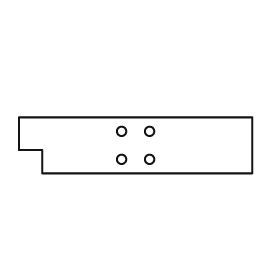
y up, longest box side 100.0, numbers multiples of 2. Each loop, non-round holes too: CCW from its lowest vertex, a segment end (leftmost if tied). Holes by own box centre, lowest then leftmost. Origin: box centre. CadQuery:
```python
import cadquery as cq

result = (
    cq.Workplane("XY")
    .moveTo(-40.0, -12.0)
    .lineTo(50.0, -12.0)
    .lineTo(50.0, 12.0)
    .lineTo(-50.0, 12.0)
    .lineTo(-50.0, -2.0)
    .lineTo(-40.0, -2.0)
    .close()
    .moveTo(-6.0, -6.0)
    .circle(2.0)
    .moveTo(6.0, -6.0)
    .circle(2.0)
    .moveTo(-6.0, 6.0)
    .circle(2.0)
    .moveTo(6.0, 6.0)
    .circle(2.0)
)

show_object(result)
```